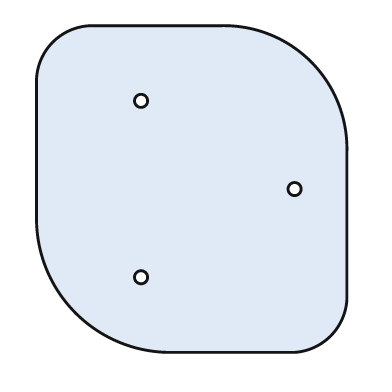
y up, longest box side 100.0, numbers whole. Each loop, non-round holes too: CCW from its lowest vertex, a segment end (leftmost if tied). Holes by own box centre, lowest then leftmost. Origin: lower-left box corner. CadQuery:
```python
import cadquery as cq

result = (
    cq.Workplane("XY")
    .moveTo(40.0, 0.0)
    .lineTo(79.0, 0.0)
    .threePointArc((90.0, 5.0), (95.0, 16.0))
    .lineTo(95.0, 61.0)
    .threePointArc((84.0, 89.0), (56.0, 100.0))
    .lineTo(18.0, 100.0)
    .threePointArc((5.0, 95.0), (0.0, 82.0))
    .lineTo(0.0, 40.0)
    .threePointArc((12.0, 12.0), (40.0, 0.0))
    .close()
    .moveTo(32.0, 23.0)
    .circle(2.0)
    .moveTo(79.0, 50.0)
    .circle(2.0)
    .moveTo(32.0, 77.0)
    .circle(2.0)
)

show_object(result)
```